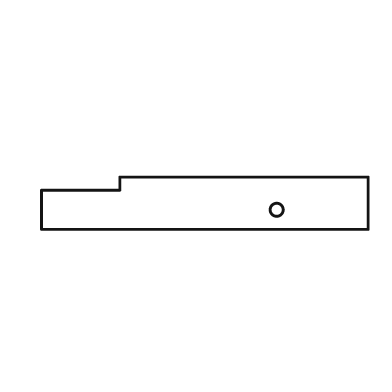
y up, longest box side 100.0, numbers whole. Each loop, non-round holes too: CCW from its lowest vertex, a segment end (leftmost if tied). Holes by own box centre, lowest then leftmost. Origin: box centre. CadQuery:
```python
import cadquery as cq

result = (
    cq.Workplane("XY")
    .moveTo(-50.0, -8.0)
    .lineTo(50.0, -8.0)
    .lineTo(50.0, 8.0)
    .lineTo(-26.0, 8.0)
    .lineTo(-26.0, 4.0)
    .lineTo(-50.0, 4.0)
    .close()
    .moveTo(22.0, -2.0)
    .circle(2.0)
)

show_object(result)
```